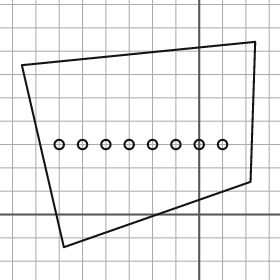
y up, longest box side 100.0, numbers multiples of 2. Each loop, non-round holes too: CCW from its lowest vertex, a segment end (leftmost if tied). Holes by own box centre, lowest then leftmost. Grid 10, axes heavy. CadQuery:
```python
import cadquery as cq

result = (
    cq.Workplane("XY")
    .moveTo(-58.0, -14.0)
    .lineTo(22.0, 14.0)
    .lineTo(24.0, 74.0)
    .lineTo(-76.0, 64.0)
    .close()
    .moveTo(-60.0, 30.0)
    .circle(2.0)
    .moveTo(-50.0, 30.0)
    .circle(2.0)
    .moveTo(-40.0, 30.0)
    .circle(2.0)
    .moveTo(-30.0, 30.0)
    .circle(2.0)
    .moveTo(-20.0, 30.0)
    .circle(2.0)
    .moveTo(-10.0, 30.0)
    .circle(2.0)
    .moveTo(0.0, 30.0)
    .circle(2.0)
    .moveTo(10.0, 30.0)
    .circle(2.0)
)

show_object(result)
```